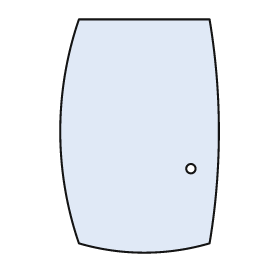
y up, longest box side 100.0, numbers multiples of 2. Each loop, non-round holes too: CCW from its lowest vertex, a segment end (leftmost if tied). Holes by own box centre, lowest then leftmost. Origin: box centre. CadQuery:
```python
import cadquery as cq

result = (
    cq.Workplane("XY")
    .moveTo(-26.0, -46.0)
    .threePointArc((2.0, -50.0), (30.0, -46.0))
    .threePointArc((34.0, 2.0), (30.0, 50.0))
    .lineTo(-26.0, 50.0)
    .threePointArc((-34.0, 2.0), (-26.0, -46.0))
    .close()
    .moveTo(22.0, -14.0)
    .circle(2.0)
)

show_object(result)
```